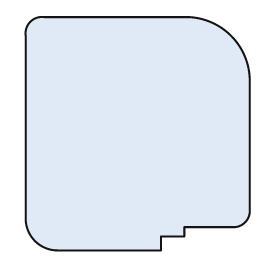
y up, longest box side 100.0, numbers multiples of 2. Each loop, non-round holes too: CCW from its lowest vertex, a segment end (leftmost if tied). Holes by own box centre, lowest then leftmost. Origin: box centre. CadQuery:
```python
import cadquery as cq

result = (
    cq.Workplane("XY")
    .moveTo(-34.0, -50.0)
    .lineTo(10.0, -50.0)
    .lineTo(10.0, -44.0)
    .lineTo(20.0, -44.0)
    .lineTo(20.0, -40.0)
    .lineTo(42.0, -40.0)
    .threePointArc((46.0, -38.0), (48.0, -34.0))
    .lineTo(48.0, 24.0)
    .threePointArc((40.0, 42.0), (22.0, 50.0))
    .lineTo(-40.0, 50.0)
    .threePointArc((-46.0, 48.0), (-48.0, 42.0))
    .lineTo(-48.0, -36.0)
    .threePointArc((-44.0, -46.0), (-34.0, -50.0))
    .close()
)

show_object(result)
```